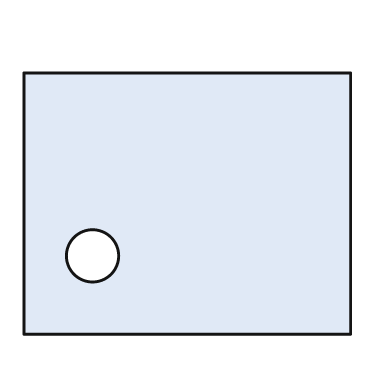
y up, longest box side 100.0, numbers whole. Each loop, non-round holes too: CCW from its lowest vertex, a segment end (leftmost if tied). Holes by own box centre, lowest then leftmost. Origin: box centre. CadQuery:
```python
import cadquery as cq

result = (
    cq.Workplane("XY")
    .moveTo(-50.0, -40.0)
    .lineTo(50.0, -40.0)
    .lineTo(50.0, 40.0)
    .lineTo(-50.0, 40.0)
    .close()
    .moveTo(-29.0, -16.0)
    .circle(8.0)
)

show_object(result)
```